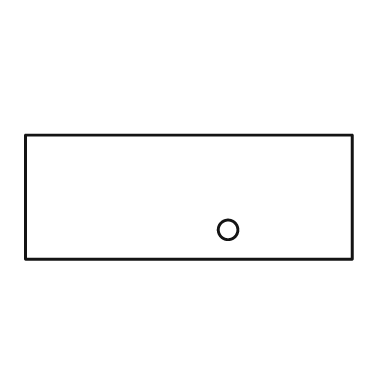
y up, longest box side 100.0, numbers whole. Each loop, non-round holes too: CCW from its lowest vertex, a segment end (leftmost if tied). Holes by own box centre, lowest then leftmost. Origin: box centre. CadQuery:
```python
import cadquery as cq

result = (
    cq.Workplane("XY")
    .moveTo(-50.0, -19.0)
    .lineTo(50.0, -19.0)
    .lineTo(50.0, 19.0)
    .lineTo(-50.0, 19.0)
    .close()
    .moveTo(12.0, -10.0)
    .circle(3.0)
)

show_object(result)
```